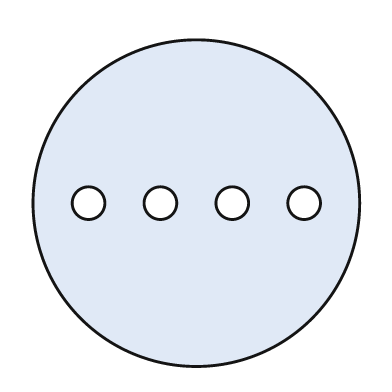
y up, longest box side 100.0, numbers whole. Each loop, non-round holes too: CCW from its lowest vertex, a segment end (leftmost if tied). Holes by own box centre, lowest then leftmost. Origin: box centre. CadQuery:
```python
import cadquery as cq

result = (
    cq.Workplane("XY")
    .moveTo(0.0, 0.0)
    .circle(50.0)
    .moveTo(-33.0, 0.0)
    .circle(5.0)
    .moveTo(-11.0, 0.0)
    .circle(5.0)
    .moveTo(11.0, 0.0)
    .circle(5.0)
    .moveTo(33.0, 0.0)
    .circle(5.0)
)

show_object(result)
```